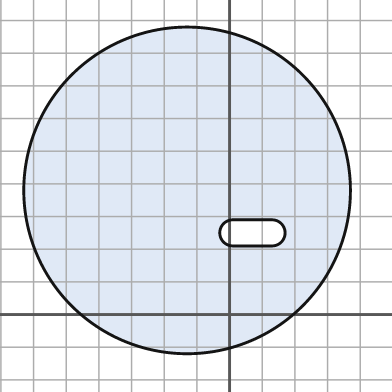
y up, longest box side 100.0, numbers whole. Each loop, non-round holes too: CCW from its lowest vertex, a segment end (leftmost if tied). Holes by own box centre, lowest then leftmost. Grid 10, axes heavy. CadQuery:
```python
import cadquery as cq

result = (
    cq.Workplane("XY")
    .moveTo(-13.0, 38.0)
    .circle(50.0)
    .moveTo(1.0, 21.0)
    .lineTo(13.0, 21.0)
    .threePointArc((17.0, 25.0), (13.0, 29.0))
    .lineTo(1.0, 29.0)
    .threePointArc((-3.0, 25.0), (1.0, 21.0))
    .close()
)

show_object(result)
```